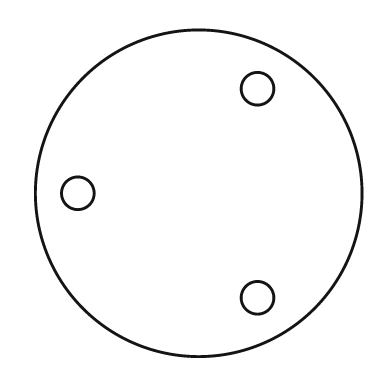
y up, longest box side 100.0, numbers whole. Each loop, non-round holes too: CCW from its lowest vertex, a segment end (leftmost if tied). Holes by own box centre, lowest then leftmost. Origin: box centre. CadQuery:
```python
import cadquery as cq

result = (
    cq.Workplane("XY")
    .moveTo(0.0, 0.0)
    .circle(50.0)
    .moveTo(18.0, -32.0)
    .circle(5.0)
    .moveTo(-37.0, 0.0)
    .circle(5.0)
    .moveTo(18.0, 32.0)
    .circle(5.0)
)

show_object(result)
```